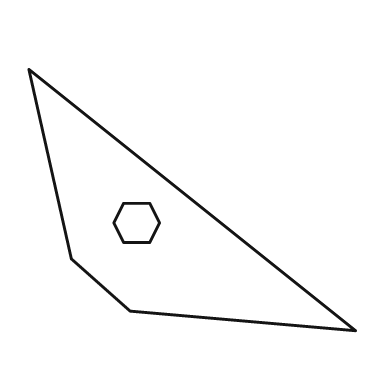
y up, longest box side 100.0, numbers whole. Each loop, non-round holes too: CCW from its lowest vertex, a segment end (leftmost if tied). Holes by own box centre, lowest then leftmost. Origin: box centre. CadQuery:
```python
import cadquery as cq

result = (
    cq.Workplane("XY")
    .moveTo(50.0, -40.0)
    .lineTo(-50.0, 40.0)
    .lineTo(-37.0, -18.0)
    .lineTo(-19.0, -34.0)
    .close()
    .moveTo(-21.0, -13.0)
    .lineTo(-13.0, -13.0)
    .lineTo(-10.0, -7.0)
    .lineTo(-13.0, -1.0)
    .lineTo(-21.0, -1.0)
    .lineTo(-24.0, -7.0)
    .close()
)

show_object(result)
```